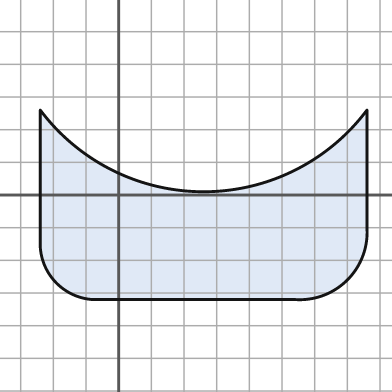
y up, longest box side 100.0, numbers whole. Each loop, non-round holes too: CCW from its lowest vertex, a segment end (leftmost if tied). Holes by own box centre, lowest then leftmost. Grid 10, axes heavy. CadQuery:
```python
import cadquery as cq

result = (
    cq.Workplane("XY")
    .moveTo(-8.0, -32.0)
    .lineTo(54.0, -32.0)
    .threePointArc((70.0, -26.0), (76.0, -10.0))
    .lineTo(76.0, 26.0)
    .threePointArc((26.0, 1.0), (-24.0, 26.0))
    .lineTo(-24.0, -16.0)
    .threePointArc((-19.0, -27.0), (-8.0, -32.0))
    .close()
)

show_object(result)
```